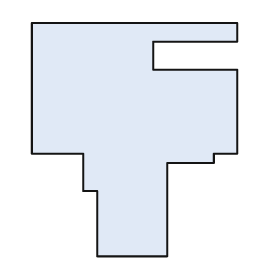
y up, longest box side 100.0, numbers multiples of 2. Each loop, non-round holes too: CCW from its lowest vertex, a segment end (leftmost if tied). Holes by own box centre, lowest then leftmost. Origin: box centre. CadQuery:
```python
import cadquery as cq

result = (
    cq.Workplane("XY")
    .moveTo(-16.0, -50.0)
    .lineTo(14.0, -50.0)
    .lineTo(14.0, -10.0)
    .lineTo(34.0, -10.0)
    .lineTo(34.0, -6.0)
    .lineTo(44.0, -6.0)
    .lineTo(44.0, 30.0)
    .lineTo(8.0, 30.0)
    .lineTo(8.0, 42.0)
    .lineTo(44.0, 42.0)
    .lineTo(44.0, 50.0)
    .lineTo(-44.0, 50.0)
    .lineTo(-44.0, -6.0)
    .lineTo(-22.0, -6.0)
    .lineTo(-22.0, -22.0)
    .lineTo(-16.0, -22.0)
    .close()
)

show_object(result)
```